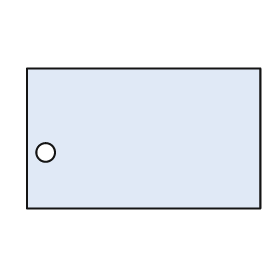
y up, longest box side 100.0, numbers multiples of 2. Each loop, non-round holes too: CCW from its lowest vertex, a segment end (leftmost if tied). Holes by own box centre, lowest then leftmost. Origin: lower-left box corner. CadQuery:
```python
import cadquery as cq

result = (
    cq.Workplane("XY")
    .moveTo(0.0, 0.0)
    .lineTo(100.0, 0.0)
    .lineTo(100.0, 60.0)
    .lineTo(0.0, 60.0)
    .close()
    .moveTo(8.0, 24.0)
    .circle(4.0)
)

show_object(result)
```